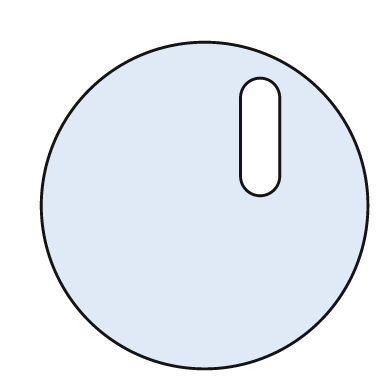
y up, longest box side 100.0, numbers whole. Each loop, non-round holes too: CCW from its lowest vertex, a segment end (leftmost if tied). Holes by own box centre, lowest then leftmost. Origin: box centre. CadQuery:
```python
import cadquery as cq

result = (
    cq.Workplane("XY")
    .moveTo(0.0, 0.0)
    .circle(50.0)
    .moveTo(11.0, 9.0)
    .threePointArc((17.0, 3.0), (23.0, 9.0))
    .lineTo(23.0, 33.0)
    .threePointArc((17.0, 39.0), (11.0, 33.0))
    .close()
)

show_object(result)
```